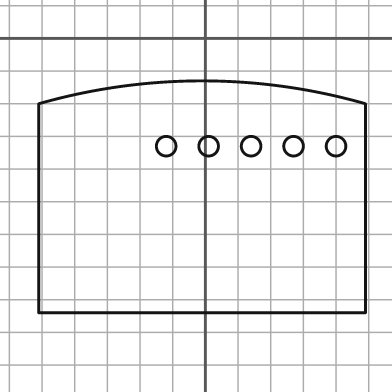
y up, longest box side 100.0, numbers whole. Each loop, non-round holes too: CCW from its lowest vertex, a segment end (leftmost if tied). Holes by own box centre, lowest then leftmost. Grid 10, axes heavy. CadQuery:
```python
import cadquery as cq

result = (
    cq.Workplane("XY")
    .moveTo(-51.0, -84.0)
    .lineTo(49.0, -84.0)
    .lineTo(49.0, -20.0)
    .threePointArc((-1.0, -13.0), (-51.0, -20.0))
    .close()
    .moveTo(-12.0, -33.0)
    .circle(3.0)
    .moveTo(1.0, -33.0)
    .circle(3.0)
    .moveTo(14.0, -33.0)
    .circle(3.0)
    .moveTo(27.0, -33.0)
    .circle(3.0)
    .moveTo(40.0, -33.0)
    .circle(3.0)
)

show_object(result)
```